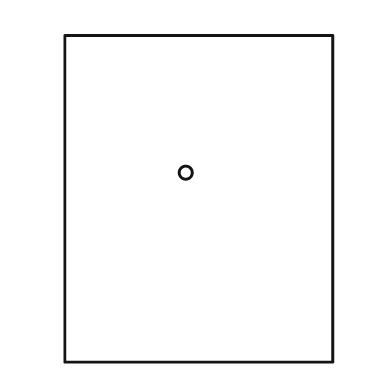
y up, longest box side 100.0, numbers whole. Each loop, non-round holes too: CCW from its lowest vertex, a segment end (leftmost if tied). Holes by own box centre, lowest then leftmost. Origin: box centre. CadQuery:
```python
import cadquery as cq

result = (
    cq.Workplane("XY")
    .moveTo(-41.0, -50.0)
    .lineTo(41.0, -50.0)
    .lineTo(41.0, 50.0)
    .lineTo(-41.0, 50.0)
    .close()
    .moveTo(-4.0, 8.0)
    .circle(2.0)
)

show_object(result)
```